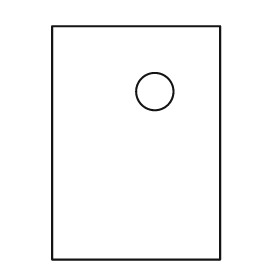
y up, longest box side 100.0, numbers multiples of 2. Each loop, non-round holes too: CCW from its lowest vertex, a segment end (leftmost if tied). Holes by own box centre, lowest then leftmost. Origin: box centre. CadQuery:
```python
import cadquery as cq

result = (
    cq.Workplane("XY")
    .moveTo(-36.0, -50.0)
    .lineTo(36.0, -50.0)
    .lineTo(36.0, 50.0)
    .lineTo(-36.0, 50.0)
    .close()
    .moveTo(8.0, 22.0)
    .circle(8.0)
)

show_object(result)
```